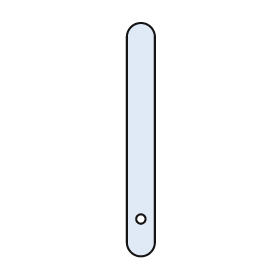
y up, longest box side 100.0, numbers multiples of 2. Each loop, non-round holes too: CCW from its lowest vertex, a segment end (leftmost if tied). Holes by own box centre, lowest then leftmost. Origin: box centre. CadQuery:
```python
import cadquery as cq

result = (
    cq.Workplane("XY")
    .moveTo(-6.0, -44.0)
    .threePointArc((0.0, -50.0), (6.0, -44.0))
    .lineTo(6.0, 44.0)
    .threePointArc((0.0, 50.0), (-6.0, 44.0))
    .close()
    .moveTo(0.0, -34.0)
    .circle(2.0)
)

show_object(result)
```